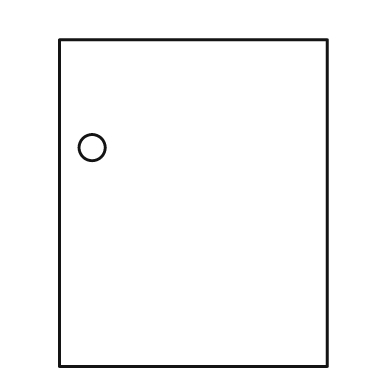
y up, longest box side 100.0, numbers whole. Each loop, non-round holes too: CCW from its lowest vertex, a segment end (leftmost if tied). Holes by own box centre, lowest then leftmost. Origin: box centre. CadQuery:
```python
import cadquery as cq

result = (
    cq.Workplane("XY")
    .moveTo(-41.0, -50.0)
    .lineTo(41.0, -50.0)
    .lineTo(41.0, 50.0)
    .lineTo(-41.0, 50.0)
    .close()
    .moveTo(-31.0, 17.0)
    .circle(4.0)
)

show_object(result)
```